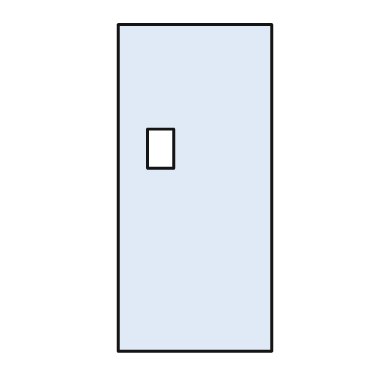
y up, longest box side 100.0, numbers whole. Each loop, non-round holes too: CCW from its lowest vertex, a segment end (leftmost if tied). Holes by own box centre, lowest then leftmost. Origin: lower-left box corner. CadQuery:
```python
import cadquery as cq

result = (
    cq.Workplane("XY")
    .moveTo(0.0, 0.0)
    .lineTo(47.0, 0.0)
    .lineTo(47.0, 100.0)
    .lineTo(0.0, 100.0)
    .close()
    .moveTo(9.0, 56.0)
    .lineTo(17.0, 56.0)
    .lineTo(17.0, 68.0)
    .lineTo(9.0, 68.0)
    .close()
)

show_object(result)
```